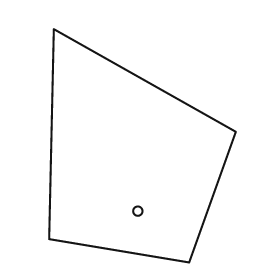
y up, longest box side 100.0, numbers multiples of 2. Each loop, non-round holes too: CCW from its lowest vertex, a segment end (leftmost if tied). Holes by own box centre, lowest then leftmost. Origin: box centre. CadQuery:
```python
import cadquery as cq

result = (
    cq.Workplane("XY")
    .moveTo(20.0, -50.0)
    .lineTo(40.0, 6.0)
    .lineTo(-38.0, 50.0)
    .lineTo(-40.0, -40.0)
    .close()
    .moveTo(-2.0, -28.0)
    .circle(2.0)
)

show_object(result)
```